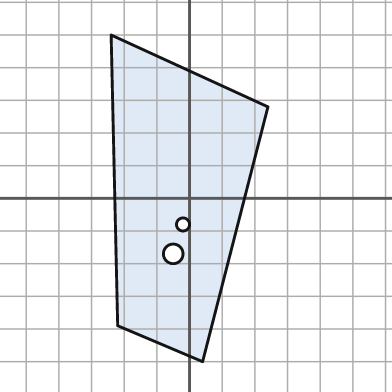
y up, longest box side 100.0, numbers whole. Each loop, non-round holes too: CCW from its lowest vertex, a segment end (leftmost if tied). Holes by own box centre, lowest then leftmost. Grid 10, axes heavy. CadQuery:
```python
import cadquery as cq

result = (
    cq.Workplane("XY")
    .moveTo(4.0, -50.0)
    .lineTo(24.0, 28.0)
    .lineTo(-24.0, 50.0)
    .lineTo(-22.0, -39.0)
    .close()
    .moveTo(-5.0, -17.0)
    .circle(3.0)
    .moveTo(-2.0, -8.0)
    .circle(2.0)
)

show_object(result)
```